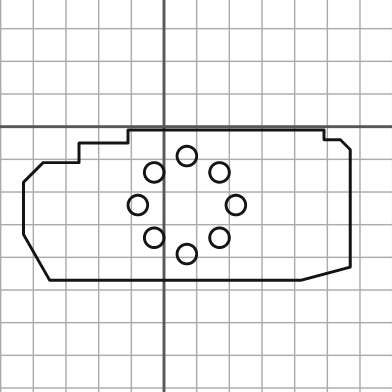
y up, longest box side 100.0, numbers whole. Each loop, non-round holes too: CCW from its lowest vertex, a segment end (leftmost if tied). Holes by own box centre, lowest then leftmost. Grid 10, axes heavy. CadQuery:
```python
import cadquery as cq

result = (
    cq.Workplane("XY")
    .moveTo(-35.0, -47.0)
    .lineTo(42.0, -47.0)
    .lineTo(57.0, -43.0)
    .lineTo(57.0, -7.0)
    .lineTo(54.0, -4.0)
    .lineTo(49.0, -4.0)
    .lineTo(49.0, -1.0)
    .lineTo(-11.0, -1.0)
    .lineTo(-11.0, -5.0)
    .lineTo(-26.0, -5.0)
    .lineTo(-26.0, -11.0)
    .lineTo(-37.0, -11.0)
    .lineTo(-43.0, -17.0)
    .lineTo(-43.0, -33.0)
    .close()
    .moveTo(7.0, -39.0)
    .circle(3.0)
    .moveTo(-3.0, -34.0)
    .circle(3.0)
    .moveTo(17.0, -34.0)
    .circle(3.0)
    .moveTo(-8.0, -24.0)
    .circle(3.0)
    .moveTo(22.0, -24.0)
    .circle(3.0)
    .moveTo(-3.0, -14.0)
    .circle(3.0)
    .moveTo(17.0, -14.0)
    .circle(3.0)
    .moveTo(7.0, -9.0)
    .circle(3.0)
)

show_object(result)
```